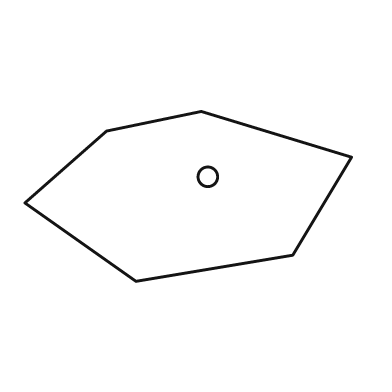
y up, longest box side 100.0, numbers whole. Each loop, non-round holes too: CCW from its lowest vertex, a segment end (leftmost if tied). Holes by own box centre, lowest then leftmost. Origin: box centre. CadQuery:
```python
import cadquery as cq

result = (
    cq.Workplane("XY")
    .moveTo(-16.0, -26.0)
    .lineTo(32.0, -18.0)
    .lineTo(50.0, 12.0)
    .lineTo(4.0, 26.0)
    .lineTo(-25.0, 20.0)
    .lineTo(-50.0, -2.0)
    .close()
    .moveTo(6.0, 6.0)
    .circle(3.0)
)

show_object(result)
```